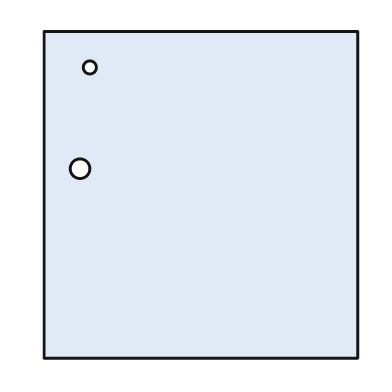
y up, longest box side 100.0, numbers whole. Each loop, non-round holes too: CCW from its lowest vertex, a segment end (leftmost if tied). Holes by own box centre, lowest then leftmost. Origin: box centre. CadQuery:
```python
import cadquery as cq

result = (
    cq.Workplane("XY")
    .moveTo(-48.0, -50.0)
    .lineTo(48.0, -50.0)
    .lineTo(48.0, 50.0)
    .lineTo(-48.0, 50.0)
    .close()
    .moveTo(-37.0, 8.0)
    .circle(3.0)
    .moveTo(-34.0, 39.0)
    .circle(2.0)
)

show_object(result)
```